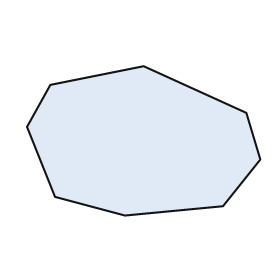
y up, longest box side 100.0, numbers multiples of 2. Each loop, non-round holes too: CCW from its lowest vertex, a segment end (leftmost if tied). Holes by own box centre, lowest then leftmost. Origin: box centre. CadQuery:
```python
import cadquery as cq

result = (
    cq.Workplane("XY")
    .moveTo(-8.0, -32.0)
    .lineTo(34.0, -28.0)
    .lineTo(50.0, -8.0)
    .lineTo(44.0, 12.0)
    .lineTo(0.0, 32.0)
    .lineTo(-40.0, 24.0)
    .lineTo(-50.0, 6.0)
    .lineTo(-38.0, -24.0)
    .close()
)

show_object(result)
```